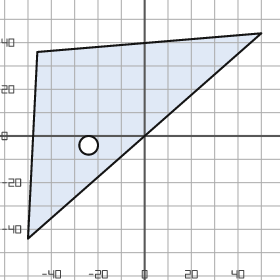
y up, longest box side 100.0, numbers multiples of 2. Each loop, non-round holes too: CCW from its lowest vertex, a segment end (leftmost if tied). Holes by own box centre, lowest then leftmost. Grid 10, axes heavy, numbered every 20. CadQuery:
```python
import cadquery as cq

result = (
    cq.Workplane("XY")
    .moveTo(-50.0, -44.0)
    .lineTo(50.0, 44.0)
    .lineTo(-46.0, 36.0)
    .close()
    .moveTo(-24.0, -4.0)
    .circle(4.0)
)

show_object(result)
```